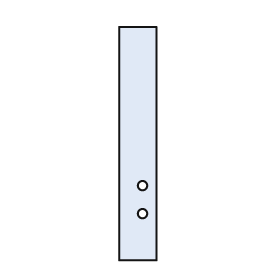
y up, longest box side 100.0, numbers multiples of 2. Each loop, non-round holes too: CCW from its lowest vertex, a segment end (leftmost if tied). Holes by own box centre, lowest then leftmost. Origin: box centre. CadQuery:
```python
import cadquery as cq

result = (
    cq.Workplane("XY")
    .moveTo(-8.0, -50.0)
    .lineTo(8.0, -50.0)
    .lineTo(8.0, 50.0)
    .lineTo(-8.0, 50.0)
    .close()
    .moveTo(2.0, -30.0)
    .circle(2.0)
    .moveTo(2.0, -18.0)
    .circle(2.0)
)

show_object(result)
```